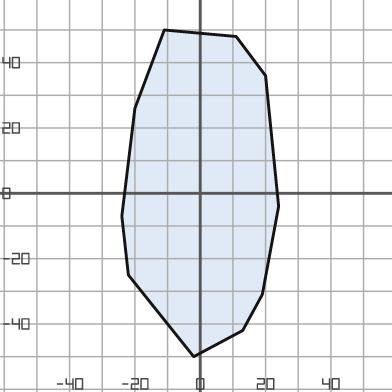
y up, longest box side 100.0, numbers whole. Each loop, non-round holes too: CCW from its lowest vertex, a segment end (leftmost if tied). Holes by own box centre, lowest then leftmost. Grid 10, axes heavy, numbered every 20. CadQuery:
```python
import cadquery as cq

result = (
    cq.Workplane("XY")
    .moveTo(-2.0, -50.0)
    .lineTo(13.0, -42.0)
    .lineTo(19.0, -31.0)
    .lineTo(24.0, -4.0)
    .lineTo(20.0, 36.0)
    .lineTo(11.0, 48.0)
    .lineTo(-11.0, 50.0)
    .lineTo(-20.0, 26.0)
    .lineTo(-24.0, -7.0)
    .lineTo(-22.0, -25.0)
    .close()
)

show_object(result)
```